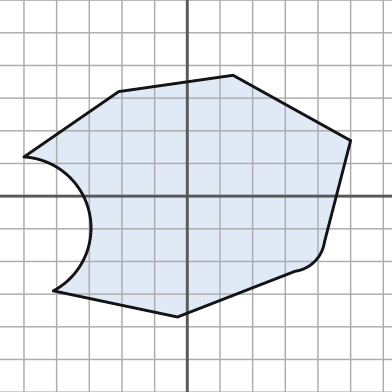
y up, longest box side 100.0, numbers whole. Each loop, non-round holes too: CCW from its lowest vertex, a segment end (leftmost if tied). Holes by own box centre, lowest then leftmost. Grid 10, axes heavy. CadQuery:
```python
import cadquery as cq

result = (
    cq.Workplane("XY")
    .moveTo(-3.0, -37.0)
    .lineTo(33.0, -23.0)
    .threePointArc((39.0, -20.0), (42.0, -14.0))
    .lineTo(50.0, 17.0)
    .lineTo(14.0, 37.0)
    .lineTo(-21.0, 32.0)
    .lineTo(-50.0, 12.0)
    .threePointArc((-30.0, -5.0), (-41.0, -29.0))
    .close()
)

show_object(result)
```